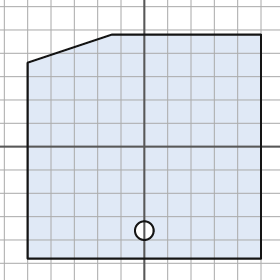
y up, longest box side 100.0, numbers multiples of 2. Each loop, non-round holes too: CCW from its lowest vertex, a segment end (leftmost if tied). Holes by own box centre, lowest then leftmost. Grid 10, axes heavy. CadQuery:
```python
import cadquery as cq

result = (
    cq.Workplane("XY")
    .moveTo(-50.0, -48.0)
    .lineTo(50.0, -48.0)
    .lineTo(50.0, 48.0)
    .lineTo(-14.0, 48.0)
    .lineTo(-50.0, 36.0)
    .close()
    .moveTo(0.0, -36.0)
    .circle(4.0)
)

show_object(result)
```